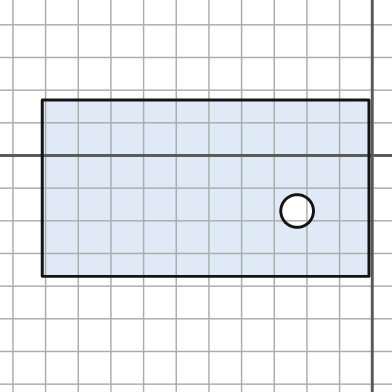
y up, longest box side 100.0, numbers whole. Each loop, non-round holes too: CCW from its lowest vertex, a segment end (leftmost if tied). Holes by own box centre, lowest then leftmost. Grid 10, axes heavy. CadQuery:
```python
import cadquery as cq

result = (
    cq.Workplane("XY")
    .moveTo(-101.0, -37.0)
    .lineTo(-1.0, -37.0)
    .lineTo(-1.0, 17.0)
    .lineTo(-101.0, 17.0)
    .close()
    .moveTo(-23.0, -17.0)
    .circle(5.0)
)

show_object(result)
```